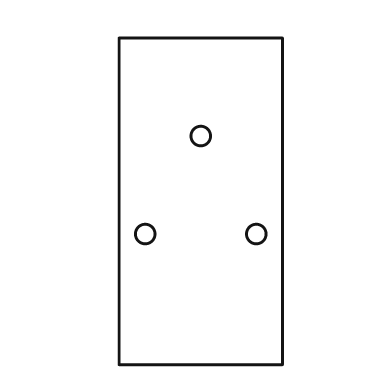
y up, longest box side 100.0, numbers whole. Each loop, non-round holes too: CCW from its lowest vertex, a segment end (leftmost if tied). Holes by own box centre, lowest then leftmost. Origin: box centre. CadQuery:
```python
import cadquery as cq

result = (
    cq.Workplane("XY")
    .moveTo(-25.0, -50.0)
    .lineTo(25.0, -50.0)
    .lineTo(25.0, 50.0)
    .lineTo(-25.0, 50.0)
    .close()
    .moveTo(-17.0, -10.0)
    .circle(3.0)
    .moveTo(17.0, -10.0)
    .circle(3.0)
    .moveTo(0.0, 20.0)
    .circle(3.0)
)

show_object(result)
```